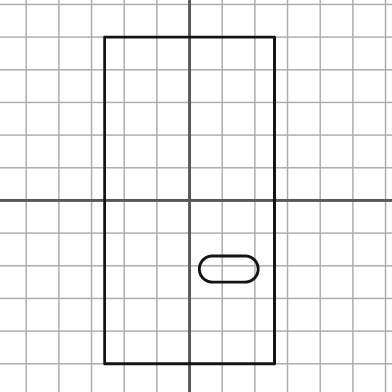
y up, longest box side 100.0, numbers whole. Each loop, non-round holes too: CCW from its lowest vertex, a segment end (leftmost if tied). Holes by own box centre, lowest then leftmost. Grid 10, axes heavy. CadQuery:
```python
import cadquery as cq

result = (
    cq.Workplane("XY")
    .moveTo(-26.0, -50.0)
    .lineTo(26.0, -50.0)
    .lineTo(26.0, 50.0)
    .lineTo(-26.0, 50.0)
    .close()
    .moveTo(7.0, -25.0)
    .lineTo(17.0, -25.0)
    .threePointArc((21.0, -21.0), (17.0, -17.0))
    .lineTo(7.0, -17.0)
    .threePointArc((3.0, -21.0), (7.0, -25.0))
    .close()
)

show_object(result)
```